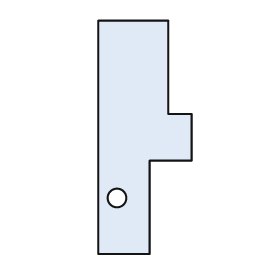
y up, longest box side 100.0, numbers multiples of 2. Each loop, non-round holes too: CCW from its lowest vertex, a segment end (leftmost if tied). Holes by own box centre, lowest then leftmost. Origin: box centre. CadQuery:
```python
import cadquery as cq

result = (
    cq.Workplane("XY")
    .moveTo(-20.0, -50.0)
    .lineTo(2.0, -50.0)
    .lineTo(2.0, -10.0)
    .lineTo(20.0, -10.0)
    .lineTo(20.0, 10.0)
    .lineTo(10.0, 10.0)
    .lineTo(10.0, 50.0)
    .lineTo(-20.0, 50.0)
    .close()
    .moveTo(-12.0, -26.0)
    .circle(4.0)
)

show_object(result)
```